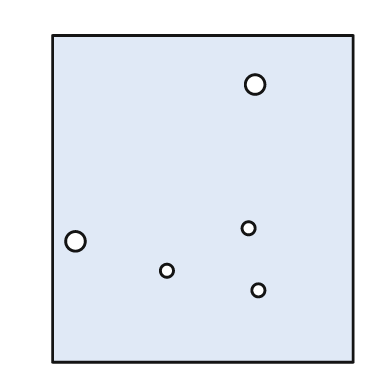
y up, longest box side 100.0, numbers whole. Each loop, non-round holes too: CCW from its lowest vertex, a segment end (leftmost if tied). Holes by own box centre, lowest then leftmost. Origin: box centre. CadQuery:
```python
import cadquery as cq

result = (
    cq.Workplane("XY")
    .moveTo(-46.0, -50.0)
    .lineTo(46.0, -50.0)
    .lineTo(46.0, 50.0)
    .lineTo(-46.0, 50.0)
    .close()
    .moveTo(17.0, -28.0)
    .circle(2.0)
    .moveTo(-11.0, -22.0)
    .circle(2.0)
    .moveTo(-39.0, -13.0)
    .circle(3.0)
    .moveTo(14.0, -9.0)
    .circle(2.0)
    .moveTo(16.0, 35.0)
    .circle(3.0)
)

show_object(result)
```